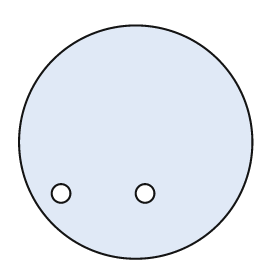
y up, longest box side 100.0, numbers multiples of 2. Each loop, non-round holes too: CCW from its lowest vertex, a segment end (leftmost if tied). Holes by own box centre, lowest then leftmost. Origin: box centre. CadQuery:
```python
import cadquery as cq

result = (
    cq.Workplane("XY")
    .moveTo(0.0, 0.0)
    .circle(50.0)
    .moveTo(-32.0, -22.0)
    .circle(4.0)
    .moveTo(4.0, -22.0)
    .circle(4.0)
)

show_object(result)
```